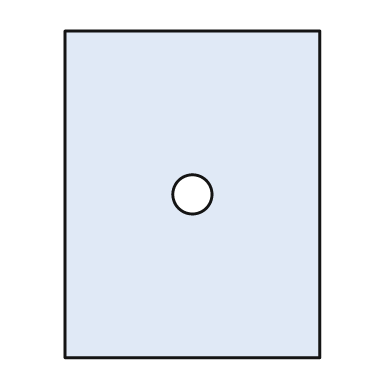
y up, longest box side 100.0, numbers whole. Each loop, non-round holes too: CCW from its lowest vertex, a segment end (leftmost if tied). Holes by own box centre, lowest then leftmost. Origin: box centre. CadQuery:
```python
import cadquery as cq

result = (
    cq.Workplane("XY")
    .moveTo(-39.0, -50.0)
    .lineTo(39.0, -50.0)
    .lineTo(39.0, 50.0)
    .lineTo(-39.0, 50.0)
    .close()
    .moveTo(0.0, 0.0)
    .circle(6.0)
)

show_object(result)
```